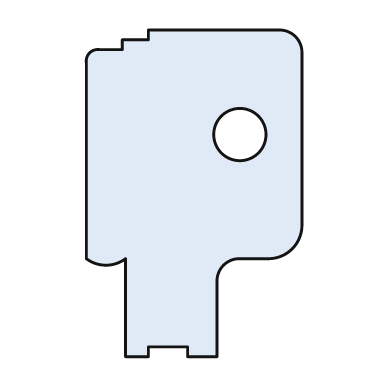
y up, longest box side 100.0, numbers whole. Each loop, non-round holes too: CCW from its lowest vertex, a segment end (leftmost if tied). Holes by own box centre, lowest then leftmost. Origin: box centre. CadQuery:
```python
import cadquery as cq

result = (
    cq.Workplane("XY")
    .moveTo(-21.0, -50.0)
    .lineTo(-14.0, -50.0)
    .lineTo(-14.0, -47.0)
    .lineTo(-2.0, -47.0)
    .lineTo(-2.0, -50.0)
    .lineTo(7.0, -50.0)
    .lineTo(7.0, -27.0)
    .threePointArc((9.0, -22.0), (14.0, -20.0))
    .lineTo(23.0, -20.0)
    .threePointArc((30.0, -17.0), (33.0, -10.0))
    .lineTo(33.0, 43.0)
    .threePointArc((31.0, 48.0), (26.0, 50.0))
    .lineTo(-14.0, 50.0)
    .lineTo(-14.0, 47.0)
    .lineTo(-22.0, 47.0)
    .lineTo(-22.0, 44.0)
    .lineTo(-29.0, 44.0)
    .threePointArc((-32.0, 43.0), (-33.0, 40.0))
    .lineTo(-33.0, -20.0)
    .threePointArc((-27.0, -22.0), (-21.0, -20.0))
    .close()
    .moveTo(14.0, 18.0)
    .circle(8.0)
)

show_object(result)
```